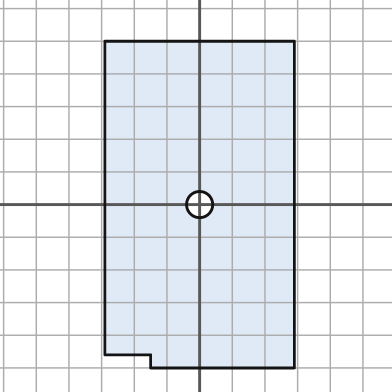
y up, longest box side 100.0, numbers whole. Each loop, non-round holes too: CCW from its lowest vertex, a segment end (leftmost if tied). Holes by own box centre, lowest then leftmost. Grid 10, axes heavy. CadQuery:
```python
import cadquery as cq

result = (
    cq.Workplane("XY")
    .moveTo(-15.0, -50.0)
    .lineTo(29.0, -50.0)
    .lineTo(29.0, 50.0)
    .lineTo(-29.0, 50.0)
    .lineTo(-29.0, -46.0)
    .lineTo(-15.0, -46.0)
    .close()
    .moveTo(0.0, 0.0)
    .circle(4.0)
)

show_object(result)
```